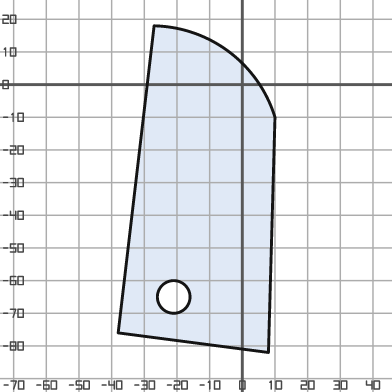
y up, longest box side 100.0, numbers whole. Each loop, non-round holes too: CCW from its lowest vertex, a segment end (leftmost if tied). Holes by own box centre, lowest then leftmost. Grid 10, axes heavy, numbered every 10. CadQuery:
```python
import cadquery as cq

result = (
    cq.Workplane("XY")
    .moveTo(8.0, -82.0)
    .lineTo(10.0, -10.0)
    .threePointArc((-4.0, 10.0), (-27.0, 18.0))
    .lineTo(-38.0, -76.0)
    .close()
    .moveTo(-21.0, -65.0)
    .circle(5.0)
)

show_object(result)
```